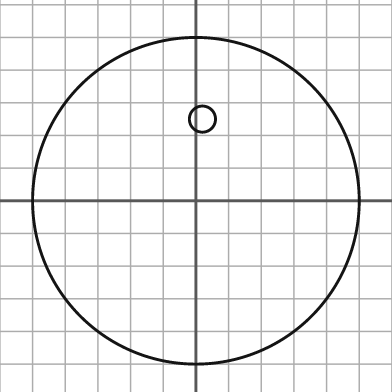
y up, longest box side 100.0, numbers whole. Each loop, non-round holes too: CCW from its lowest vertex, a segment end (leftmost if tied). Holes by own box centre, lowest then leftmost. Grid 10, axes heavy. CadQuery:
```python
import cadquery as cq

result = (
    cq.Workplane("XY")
    .moveTo(0.0, 0.0)
    .circle(50.0)
    .moveTo(2.0, 25.0)
    .circle(4.0)
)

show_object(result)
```